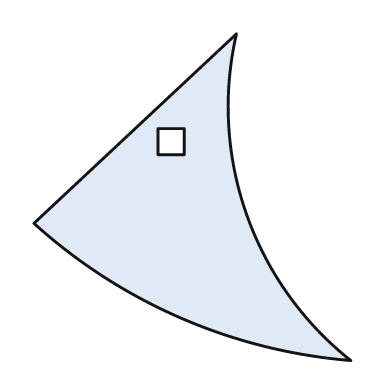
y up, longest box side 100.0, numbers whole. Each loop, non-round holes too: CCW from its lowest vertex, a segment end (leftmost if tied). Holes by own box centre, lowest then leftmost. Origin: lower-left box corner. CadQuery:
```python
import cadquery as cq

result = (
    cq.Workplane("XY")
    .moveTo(97.0, 0.0)
    .threePointArc((65.0, 45.0), (62.0, 100.0))
    .lineTo(0.0, 42.0)
    .threePointArc((45.0, 13.0), (97.0, 0.0))
    .close()
    .moveTo(38.0, 63.0)
    .lineTo(46.0, 63.0)
    .lineTo(46.0, 71.0)
    .lineTo(38.0, 71.0)
    .close()
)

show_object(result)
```